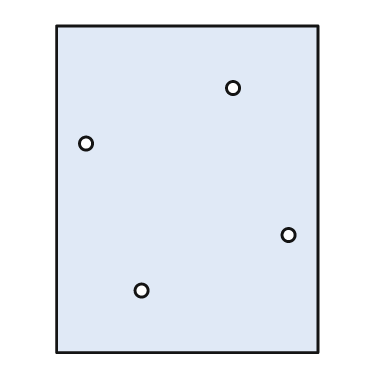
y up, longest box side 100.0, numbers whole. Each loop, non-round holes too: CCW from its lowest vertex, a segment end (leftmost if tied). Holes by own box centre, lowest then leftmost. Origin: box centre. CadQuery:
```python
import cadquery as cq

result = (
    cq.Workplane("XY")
    .moveTo(-40.0, -50.0)
    .lineTo(40.0, -50.0)
    .lineTo(40.0, 50.0)
    .lineTo(-40.0, 50.0)
    .close()
    .moveTo(-14.0, -31.0)
    .circle(2.0)
    .moveTo(31.0, -14.0)
    .circle(2.0)
    .moveTo(-31.0, 14.0)
    .circle(2.0)
    .moveTo(14.0, 31.0)
    .circle(2.0)
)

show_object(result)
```